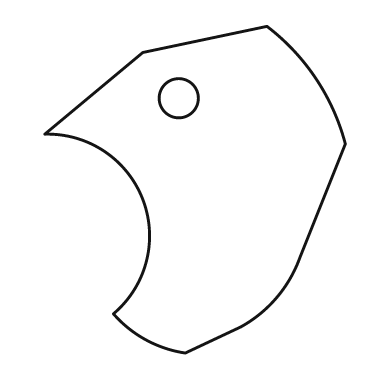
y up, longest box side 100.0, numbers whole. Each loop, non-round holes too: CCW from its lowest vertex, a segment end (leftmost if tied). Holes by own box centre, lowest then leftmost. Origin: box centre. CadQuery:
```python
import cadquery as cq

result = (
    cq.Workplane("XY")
    .moveTo(-3.0, -50.0)
    .lineTo(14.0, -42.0)
    .threePointArc((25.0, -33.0), (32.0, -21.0))
    .lineTo(46.0, 14.0)
    .threePointArc((37.0, 34.0), (22.0, 50.0))
    .lineTo(-16.0, 42.0)
    .lineTo(-46.0, 17.0)
    .threePointArc((-16.0, -3.0), (-25.0, -38.0))
    .threePointArc((-15.0, -46.0), (-3.0, -50.0))
    .close()
    .moveTo(-5.0, 28.0)
    .circle(6.0)
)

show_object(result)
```